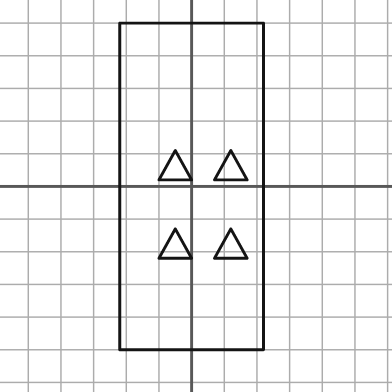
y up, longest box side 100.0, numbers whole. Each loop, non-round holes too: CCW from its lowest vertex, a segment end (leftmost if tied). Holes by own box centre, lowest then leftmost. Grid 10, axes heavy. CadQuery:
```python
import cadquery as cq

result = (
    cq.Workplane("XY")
    .moveTo(-22.0, -50.0)
    .lineTo(22.0, -50.0)
    .lineTo(22.0, 50.0)
    .lineTo(-22.0, 50.0)
    .close()
    .moveTo(-10.0, -22.0)
    .lineTo(0.0, -22.0)
    .lineTo(-5.0, -13.0)
    .close()
    .moveTo(7.0, -22.0)
    .lineTo(17.0, -22.0)
    .lineTo(12.0, -13.0)
    .close()
    .moveTo(-10.0, 2.0)
    .lineTo(0.0, 2.0)
    .lineTo(-5.0, 11.0)
    .close()
    .moveTo(7.0, 2.0)
    .lineTo(17.0, 2.0)
    .lineTo(12.0, 11.0)
    .close()
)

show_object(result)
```